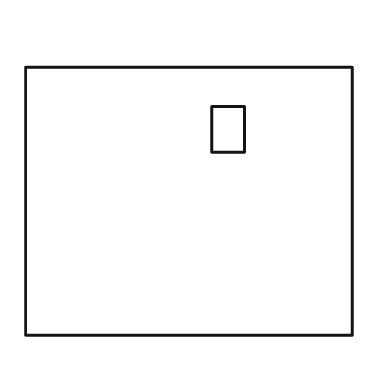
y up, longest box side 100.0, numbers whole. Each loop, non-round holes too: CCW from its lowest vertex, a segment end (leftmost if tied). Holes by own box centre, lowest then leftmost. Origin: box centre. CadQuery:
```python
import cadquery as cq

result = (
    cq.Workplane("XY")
    .moveTo(-50.0, -41.0)
    .lineTo(50.0, -41.0)
    .lineTo(50.0, 41.0)
    .lineTo(-50.0, 41.0)
    .close()
    .moveTo(7.0, 15.0)
    .lineTo(17.0, 15.0)
    .lineTo(17.0, 29.0)
    .lineTo(7.0, 29.0)
    .close()
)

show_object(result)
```